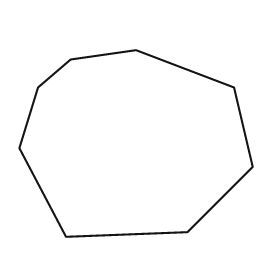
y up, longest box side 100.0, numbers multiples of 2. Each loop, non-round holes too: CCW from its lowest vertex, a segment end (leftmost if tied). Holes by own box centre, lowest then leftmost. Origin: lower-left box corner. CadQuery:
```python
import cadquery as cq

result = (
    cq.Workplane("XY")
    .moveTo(20.0, 0.0)
    .lineTo(72.0, 2.0)
    .lineTo(100.0, 30.0)
    .lineTo(92.0, 64.0)
    .lineTo(50.0, 80.0)
    .lineTo(22.0, 76.0)
    .lineTo(8.0, 64.0)
    .lineTo(0.0, 38.0)
    .close()
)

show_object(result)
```